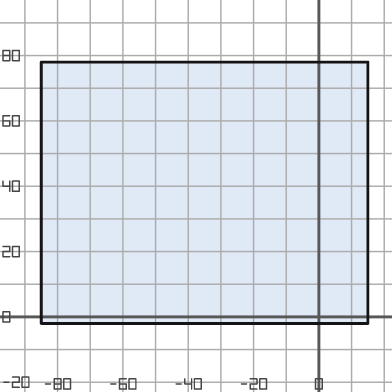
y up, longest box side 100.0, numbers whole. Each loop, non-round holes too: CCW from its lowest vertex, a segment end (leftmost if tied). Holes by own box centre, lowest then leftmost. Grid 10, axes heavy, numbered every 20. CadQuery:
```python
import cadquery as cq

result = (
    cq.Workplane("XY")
    .moveTo(-85.0, -2.0)
    .lineTo(15.0, -2.0)
    .lineTo(15.0, 78.0)
    .lineTo(-85.0, 78.0)
    .close()
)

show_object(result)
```